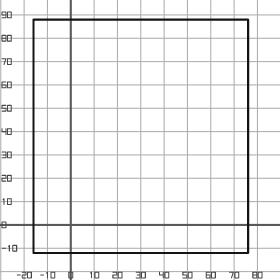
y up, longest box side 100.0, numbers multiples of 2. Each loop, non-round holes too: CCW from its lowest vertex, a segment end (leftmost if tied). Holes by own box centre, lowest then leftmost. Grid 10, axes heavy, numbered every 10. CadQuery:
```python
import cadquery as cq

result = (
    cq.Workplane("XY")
    .moveTo(-16.0, -12.0)
    .lineTo(76.0, -12.0)
    .lineTo(76.0, 88.0)
    .lineTo(-16.0, 88.0)
    .close()
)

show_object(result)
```